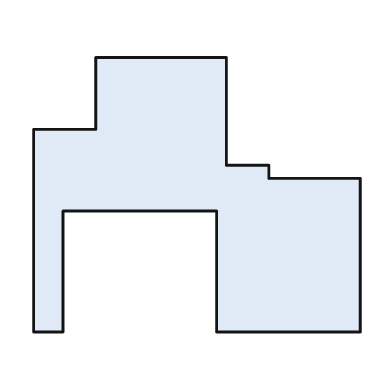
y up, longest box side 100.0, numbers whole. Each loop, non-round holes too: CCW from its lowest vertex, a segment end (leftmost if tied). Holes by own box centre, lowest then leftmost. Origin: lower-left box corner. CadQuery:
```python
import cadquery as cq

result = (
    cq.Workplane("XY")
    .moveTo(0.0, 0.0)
    .lineTo(9.0, 0.0)
    .lineTo(9.0, 37.0)
    .lineTo(56.0, 37.0)
    .lineTo(56.0, 0.0)
    .lineTo(100.0, 0.0)
    .lineTo(100.0, 47.0)
    .lineTo(72.0, 47.0)
    .lineTo(72.0, 51.0)
    .lineTo(59.0, 51.0)
    .lineTo(59.0, 84.0)
    .lineTo(19.0, 84.0)
    .lineTo(19.0, 62.0)
    .lineTo(0.0, 62.0)
    .close()
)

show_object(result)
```